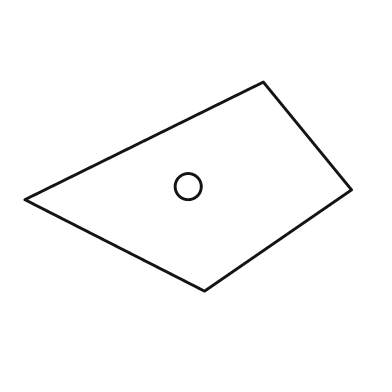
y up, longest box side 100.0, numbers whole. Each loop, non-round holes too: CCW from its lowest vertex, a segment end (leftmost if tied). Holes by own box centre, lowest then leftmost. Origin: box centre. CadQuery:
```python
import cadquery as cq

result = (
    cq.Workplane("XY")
    .moveTo(5.0, -32.0)
    .lineTo(50.0, -1.0)
    .lineTo(23.0, 32.0)
    .lineTo(-50.0, -4.0)
    .close()
    .moveTo(0.0, 0.0)
    .circle(4.0)
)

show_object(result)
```